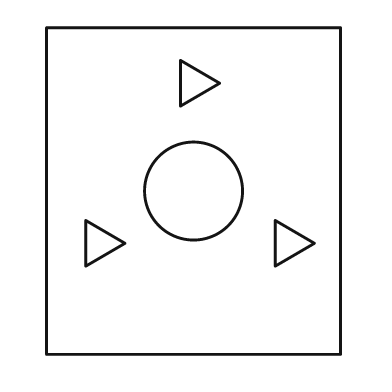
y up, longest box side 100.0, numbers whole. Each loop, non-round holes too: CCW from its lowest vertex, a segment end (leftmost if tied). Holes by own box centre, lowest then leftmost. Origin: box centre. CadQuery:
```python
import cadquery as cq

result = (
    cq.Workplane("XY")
    .moveTo(-45.0, -50.0)
    .lineTo(45.0, -50.0)
    .lineTo(45.0, 50.0)
    .lineTo(-45.0, 50.0)
    .close()
    .moveTo(-33.0, -23.0)
    .lineTo(-21.0, -16.0)
    .lineTo(-33.0, -9.0)
    .close()
    .moveTo(25.0, -23.0)
    .lineTo(37.0, -16.0)
    .lineTo(25.0, -9.0)
    .close()
    .moveTo(0.0, 0.0)
    .circle(15.0)
    .moveTo(-4.0, 26.0)
    .lineTo(8.0, 33.0)
    .lineTo(-4.0, 40.0)
    .close()
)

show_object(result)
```